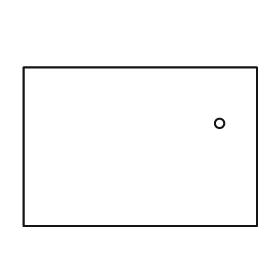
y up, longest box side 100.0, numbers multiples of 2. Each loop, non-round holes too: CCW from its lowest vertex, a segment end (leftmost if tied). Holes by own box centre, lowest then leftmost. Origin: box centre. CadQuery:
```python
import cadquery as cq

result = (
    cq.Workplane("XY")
    .moveTo(-50.0, -34.0)
    .lineTo(50.0, -34.0)
    .lineTo(50.0, 34.0)
    .lineTo(-50.0, 34.0)
    .close()
    .moveTo(34.0, 10.0)
    .circle(2.0)
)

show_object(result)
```